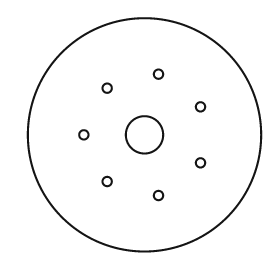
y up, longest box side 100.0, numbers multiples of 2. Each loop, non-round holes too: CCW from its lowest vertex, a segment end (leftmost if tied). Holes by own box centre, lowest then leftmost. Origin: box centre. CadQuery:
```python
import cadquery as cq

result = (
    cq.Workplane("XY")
    .moveTo(0.0, 0.0)
    .circle(50.0)
    .moveTo(6.0, -26.0)
    .circle(2.0)
    .moveTo(-16.0, -20.0)
    .circle(2.0)
    .moveTo(24.0, -12.0)
    .circle(2.0)
    .moveTo(-26.0, 0.0)
    .circle(2.0)
    .moveTo(0.0, 0.0)
    .circle(8.0)
    .moveTo(24.0, 12.0)
    .circle(2.0)
    .moveTo(-16.0, 20.0)
    .circle(2.0)
    .moveTo(6.0, 26.0)
    .circle(2.0)
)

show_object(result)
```